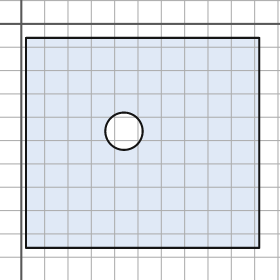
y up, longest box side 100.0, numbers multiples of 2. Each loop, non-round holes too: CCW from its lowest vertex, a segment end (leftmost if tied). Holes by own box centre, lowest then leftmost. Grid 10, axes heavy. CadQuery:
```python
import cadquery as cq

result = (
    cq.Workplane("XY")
    .moveTo(2.0, -96.0)
    .lineTo(102.0, -96.0)
    .lineTo(102.0, -6.0)
    .lineTo(2.0, -6.0)
    .close()
    .moveTo(44.0, -46.0)
    .circle(8.0)
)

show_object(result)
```